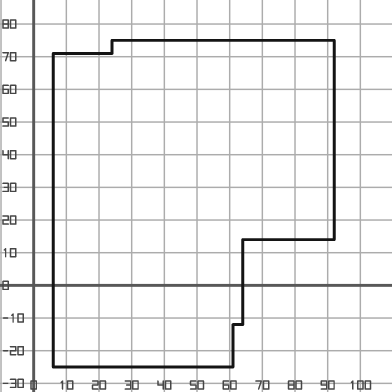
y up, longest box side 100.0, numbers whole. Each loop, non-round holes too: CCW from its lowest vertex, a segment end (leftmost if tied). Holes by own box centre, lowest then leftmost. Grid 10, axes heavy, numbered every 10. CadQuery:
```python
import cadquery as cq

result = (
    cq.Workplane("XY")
    .moveTo(6.0, -25.0)
    .lineTo(61.0, -25.0)
    .lineTo(61.0, -12.0)
    .lineTo(64.0, -12.0)
    .lineTo(64.0, 14.0)
    .lineTo(92.0, 14.0)
    .lineTo(92.0, 75.0)
    .lineTo(24.0, 75.0)
    .lineTo(24.0, 71.0)
    .lineTo(6.0, 71.0)
    .close()
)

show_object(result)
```